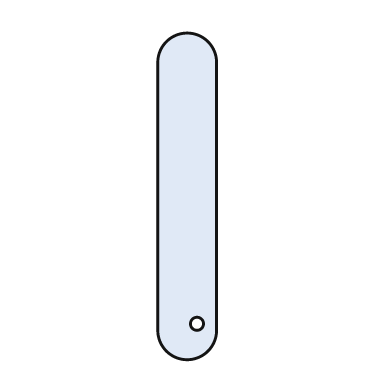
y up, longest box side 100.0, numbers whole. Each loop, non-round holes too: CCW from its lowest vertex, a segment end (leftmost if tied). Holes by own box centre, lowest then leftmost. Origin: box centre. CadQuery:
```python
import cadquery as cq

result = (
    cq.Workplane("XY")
    .moveTo(-9.0, -41.0)
    .threePointArc((0.0, -50.0), (9.0, -41.0))
    .lineTo(9.0, 41.0)
    .threePointArc((0.0, 50.0), (-9.0, 41.0))
    .close()
    .moveTo(3.0, -39.0)
    .circle(2.0)
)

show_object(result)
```